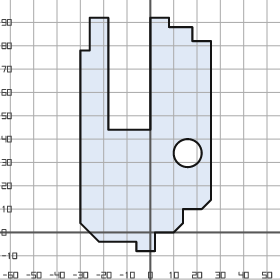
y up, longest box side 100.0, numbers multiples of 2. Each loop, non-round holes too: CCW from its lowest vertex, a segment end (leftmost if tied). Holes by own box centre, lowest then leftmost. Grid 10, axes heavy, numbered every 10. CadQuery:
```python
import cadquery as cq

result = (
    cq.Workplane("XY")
    .moveTo(-6.0, -8.0)
    .lineTo(2.0, -8.0)
    .lineTo(2.0, 0.0)
    .lineTo(10.0, 0.0)
    .lineTo(14.0, 4.0)
    .lineTo(14.0, 10.0)
    .lineTo(22.0, 10.0)
    .lineTo(26.0, 14.0)
    .lineTo(26.0, 82.0)
    .lineTo(18.0, 82.0)
    .lineTo(18.0, 88.0)
    .lineTo(8.0, 88.0)
    .lineTo(8.0, 92.0)
    .lineTo(0.0, 92.0)
    .lineTo(0.0, 44.0)
    .lineTo(-18.0, 44.0)
    .lineTo(-18.0, 92.0)
    .lineTo(-26.0, 92.0)
    .lineTo(-26.0, 78.0)
    .lineTo(-30.0, 78.0)
    .lineTo(-30.0, 4.0)
    .lineTo(-22.0, -4.0)
    .lineTo(-6.0, -4.0)
    .close()
    .moveTo(16.0, 34.0)
    .circle(6.0)
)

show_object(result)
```